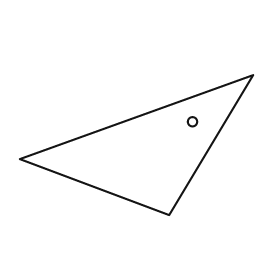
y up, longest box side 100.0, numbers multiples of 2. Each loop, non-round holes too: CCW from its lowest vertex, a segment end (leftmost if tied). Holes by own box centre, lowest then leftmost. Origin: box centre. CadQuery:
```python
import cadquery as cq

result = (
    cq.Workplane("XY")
    .moveTo(14.0, -30.0)
    .lineTo(50.0, 30.0)
    .lineTo(-50.0, -6.0)
    .close()
    .moveTo(24.0, 10.0)
    .circle(2.0)
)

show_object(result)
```